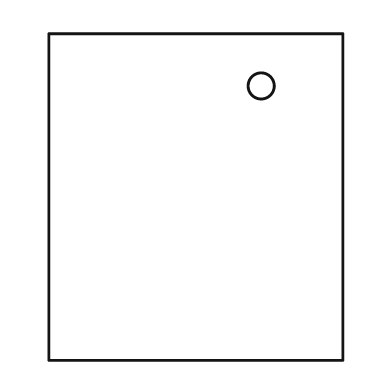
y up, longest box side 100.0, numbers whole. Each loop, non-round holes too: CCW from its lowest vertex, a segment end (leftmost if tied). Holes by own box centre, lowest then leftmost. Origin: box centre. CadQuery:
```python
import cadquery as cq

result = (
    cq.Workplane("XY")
    .moveTo(-45.0, -50.0)
    .lineTo(45.0, -50.0)
    .lineTo(45.0, 50.0)
    .lineTo(-45.0, 50.0)
    .close()
    .moveTo(20.0, 34.0)
    .circle(4.0)
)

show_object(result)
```